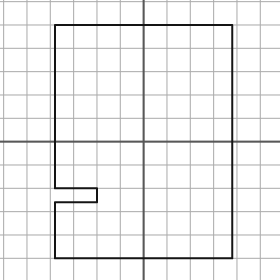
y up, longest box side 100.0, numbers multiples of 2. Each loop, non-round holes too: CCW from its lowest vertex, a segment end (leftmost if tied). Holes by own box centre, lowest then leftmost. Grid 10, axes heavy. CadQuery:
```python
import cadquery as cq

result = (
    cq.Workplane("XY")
    .moveTo(-38.0, -50.0)
    .lineTo(38.0, -50.0)
    .lineTo(38.0, 50.0)
    .lineTo(-38.0, 50.0)
    .lineTo(-38.0, -20.0)
    .lineTo(-20.0, -20.0)
    .lineTo(-20.0, -26.0)
    .lineTo(-38.0, -26.0)
    .close()
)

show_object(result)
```